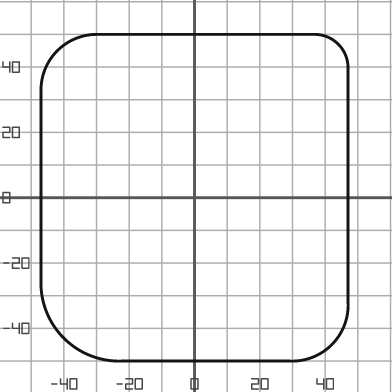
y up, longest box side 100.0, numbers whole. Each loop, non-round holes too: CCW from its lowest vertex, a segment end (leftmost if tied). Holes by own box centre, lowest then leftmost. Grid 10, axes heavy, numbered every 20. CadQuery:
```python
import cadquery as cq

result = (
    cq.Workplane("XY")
    .moveTo(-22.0, -50.0)
    .lineTo(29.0, -50.0)
    .threePointArc((42.0, -45.0), (47.0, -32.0))
    .lineTo(47.0, 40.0)
    .threePointArc((44.0, 47.0), (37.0, 50.0))
    .lineTo(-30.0, 50.0)
    .threePointArc((-42.0, 45.0), (-47.0, 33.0))
    .lineTo(-47.0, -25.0)
    .threePointArc((-40.0, -43.0), (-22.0, -50.0))
    .close()
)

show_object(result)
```